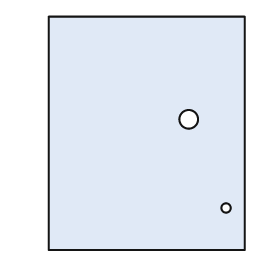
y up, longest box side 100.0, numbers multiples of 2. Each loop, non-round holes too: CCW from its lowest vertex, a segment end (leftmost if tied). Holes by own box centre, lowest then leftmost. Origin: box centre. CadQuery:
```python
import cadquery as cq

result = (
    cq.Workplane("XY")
    .moveTo(-42.0, -50.0)
    .lineTo(42.0, -50.0)
    .lineTo(42.0, 50.0)
    .lineTo(-42.0, 50.0)
    .close()
    .moveTo(34.0, -32.0)
    .circle(2.0)
    .moveTo(18.0, 6.0)
    .circle(4.0)
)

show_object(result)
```